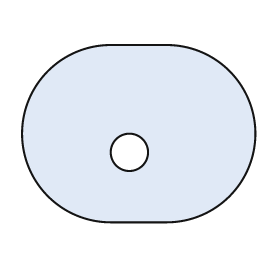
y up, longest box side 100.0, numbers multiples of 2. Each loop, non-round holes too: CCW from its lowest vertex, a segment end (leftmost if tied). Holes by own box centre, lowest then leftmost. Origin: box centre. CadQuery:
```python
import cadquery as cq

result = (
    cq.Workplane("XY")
    .moveTo(-12.0, -38.0)
    .lineTo(12.0, -38.0)
    .threePointArc((50.0, 0.0), (12.0, 38.0))
    .lineTo(-12.0, 38.0)
    .threePointArc((-50.0, 0.0), (-12.0, -38.0))
    .close()
    .moveTo(-4.0, -8.0)
    .circle(8.0)
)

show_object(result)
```